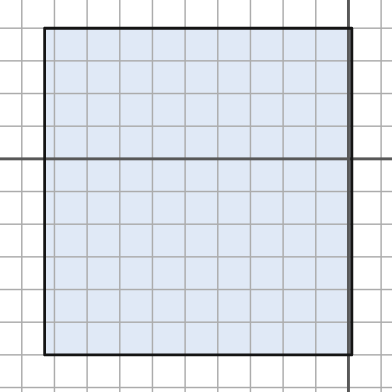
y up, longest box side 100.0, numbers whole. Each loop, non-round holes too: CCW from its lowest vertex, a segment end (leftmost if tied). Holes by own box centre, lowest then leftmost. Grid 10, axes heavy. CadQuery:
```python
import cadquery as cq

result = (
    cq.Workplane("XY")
    .moveTo(-93.0, -60.0)
    .lineTo(1.0, -60.0)
    .lineTo(1.0, 40.0)
    .lineTo(-93.0, 40.0)
    .close()
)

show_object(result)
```